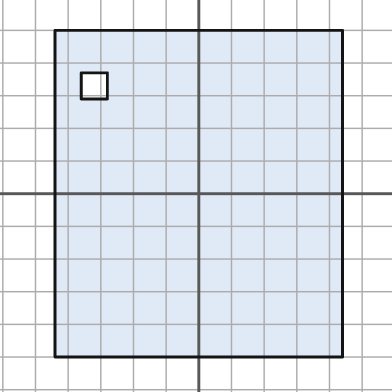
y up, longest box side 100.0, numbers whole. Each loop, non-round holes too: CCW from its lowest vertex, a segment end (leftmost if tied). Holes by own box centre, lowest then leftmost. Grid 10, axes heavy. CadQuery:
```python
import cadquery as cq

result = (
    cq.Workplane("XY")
    .moveTo(-44.0, -50.0)
    .lineTo(44.0, -50.0)
    .lineTo(44.0, 50.0)
    .lineTo(-44.0, 50.0)
    .close()
    .moveTo(-36.0, 29.0)
    .lineTo(-28.0, 29.0)
    .lineTo(-28.0, 37.0)
    .lineTo(-36.0, 37.0)
    .close()
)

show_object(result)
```